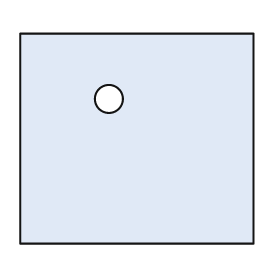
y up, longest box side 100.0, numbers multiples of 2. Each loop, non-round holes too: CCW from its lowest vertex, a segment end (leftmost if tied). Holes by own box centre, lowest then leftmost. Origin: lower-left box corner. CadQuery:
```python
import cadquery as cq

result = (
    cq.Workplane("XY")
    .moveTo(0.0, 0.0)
    .lineTo(100.0, 0.0)
    .lineTo(100.0, 90.0)
    .lineTo(0.0, 90.0)
    .close()
    .moveTo(38.0, 62.0)
    .circle(6.0)
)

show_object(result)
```